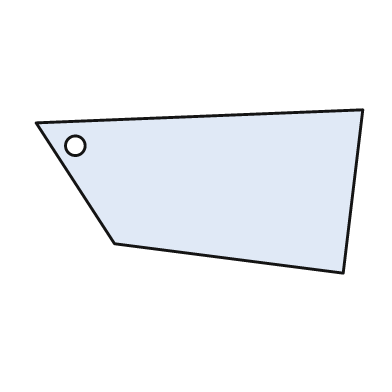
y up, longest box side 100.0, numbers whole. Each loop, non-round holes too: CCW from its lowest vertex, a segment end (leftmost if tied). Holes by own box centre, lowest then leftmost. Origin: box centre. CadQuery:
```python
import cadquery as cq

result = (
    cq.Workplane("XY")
    .moveTo(44.0, -25.0)
    .lineTo(50.0, 25.0)
    .lineTo(-50.0, 21.0)
    .lineTo(-26.0, -16.0)
    .close()
    .moveTo(-38.0, 14.0)
    .circle(3.0)
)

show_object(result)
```